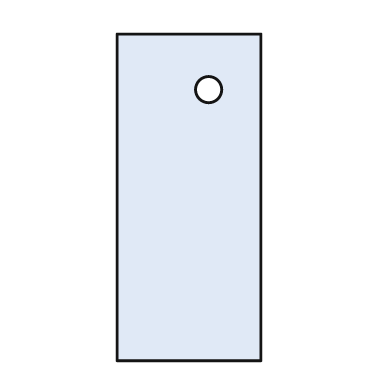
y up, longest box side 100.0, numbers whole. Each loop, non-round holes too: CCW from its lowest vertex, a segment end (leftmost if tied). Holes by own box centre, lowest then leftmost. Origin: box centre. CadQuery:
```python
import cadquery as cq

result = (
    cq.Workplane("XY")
    .moveTo(-22.0, -50.0)
    .lineTo(22.0, -50.0)
    .lineTo(22.0, 50.0)
    .lineTo(-22.0, 50.0)
    .close()
    .moveTo(6.0, 33.0)
    .circle(4.0)
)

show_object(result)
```